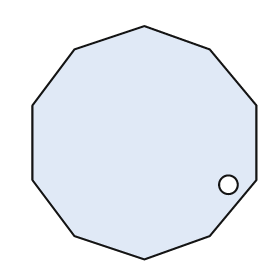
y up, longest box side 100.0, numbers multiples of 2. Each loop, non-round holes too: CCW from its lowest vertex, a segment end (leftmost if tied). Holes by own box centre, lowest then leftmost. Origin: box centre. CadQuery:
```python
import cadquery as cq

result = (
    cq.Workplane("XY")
    .moveTo(0.0, -50.0)
    .lineTo(28.0, -40.0)
    .lineTo(48.0, -16.0)
    .lineTo(48.0, 16.0)
    .lineTo(28.0, 40.0)
    .lineTo(0.0, 50.0)
    .lineTo(-30.0, 40.0)
    .lineTo(-48.0, 16.0)
    .lineTo(-48.0, -16.0)
    .lineTo(-30.0, -40.0)
    .close()
    .moveTo(36.0, -18.0)
    .circle(4.0)
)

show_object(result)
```